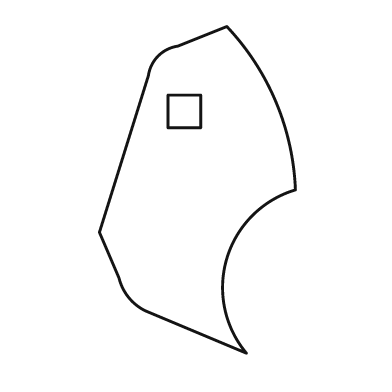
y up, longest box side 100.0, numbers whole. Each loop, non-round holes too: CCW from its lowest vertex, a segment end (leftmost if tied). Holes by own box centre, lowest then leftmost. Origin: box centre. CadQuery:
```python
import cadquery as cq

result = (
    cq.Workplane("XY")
    .moveTo(15.0, -50.0)
    .threePointArc((9.0, -21.0), (30.0, 0.0))
    .threePointArc((24.0, 27.0), (9.0, 50.0))
    .lineTo(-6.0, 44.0)
    .threePointArc((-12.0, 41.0), (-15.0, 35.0))
    .lineTo(-30.0, -13.0)
    .lineTo(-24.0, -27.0)
    .threePointArc((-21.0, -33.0), (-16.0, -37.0))
    .close()
    .moveTo(-9.0, 19.0)
    .lineTo(1.0, 19.0)
    .lineTo(1.0, 29.0)
    .lineTo(-9.0, 29.0)
    .close()
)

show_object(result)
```